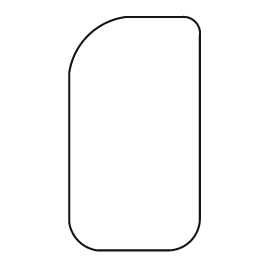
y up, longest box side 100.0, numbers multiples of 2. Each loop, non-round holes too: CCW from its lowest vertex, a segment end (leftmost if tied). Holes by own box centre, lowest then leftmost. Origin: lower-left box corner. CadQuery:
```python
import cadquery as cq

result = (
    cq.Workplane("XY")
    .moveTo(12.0, 0.0)
    .lineTo(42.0, 0.0)
    .threePointArc((52.0, 4.0), (56.0, 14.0))
    .lineTo(56.0, 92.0)
    .threePointArc((54.0, 98.0), (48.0, 100.0))
    .lineTo(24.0, 100.0)
    .threePointArc((8.0, 92.0), (0.0, 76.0))
    .lineTo(0.0, 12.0)
    .threePointArc((4.0, 4.0), (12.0, 0.0))
    .close()
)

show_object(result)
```